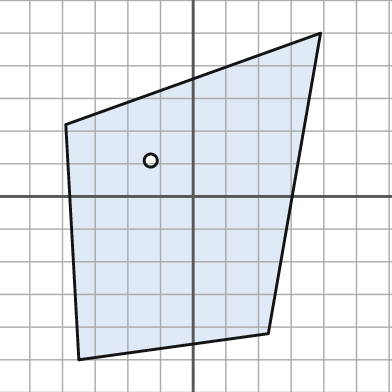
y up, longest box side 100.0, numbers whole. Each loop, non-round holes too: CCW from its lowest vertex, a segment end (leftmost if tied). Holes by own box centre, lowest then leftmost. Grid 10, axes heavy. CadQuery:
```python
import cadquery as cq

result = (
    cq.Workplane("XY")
    .moveTo(-35.0, -50.0)
    .lineTo(23.0, -42.0)
    .lineTo(39.0, 50.0)
    .lineTo(-39.0, 22.0)
    .close()
    .moveTo(-13.0, 11.0)
    .circle(2.0)
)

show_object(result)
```